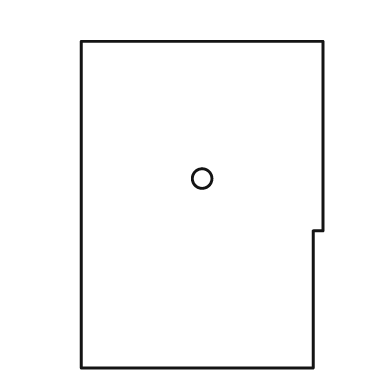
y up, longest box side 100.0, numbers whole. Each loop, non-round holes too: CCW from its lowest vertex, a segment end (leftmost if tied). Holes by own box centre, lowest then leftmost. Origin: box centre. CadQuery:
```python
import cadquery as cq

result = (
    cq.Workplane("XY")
    .moveTo(-37.0, -50.0)
    .lineTo(34.0, -50.0)
    .lineTo(34.0, -8.0)
    .lineTo(37.0, -8.0)
    .lineTo(37.0, 50.0)
    .lineTo(-37.0, 50.0)
    .close()
    .moveTo(0.0, 8.0)
    .circle(3.0)
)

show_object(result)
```